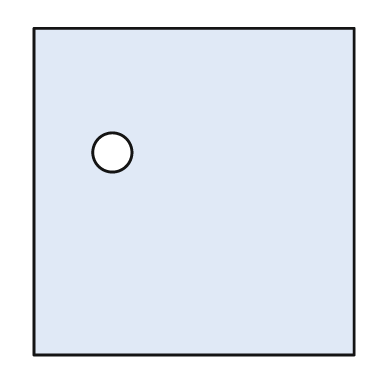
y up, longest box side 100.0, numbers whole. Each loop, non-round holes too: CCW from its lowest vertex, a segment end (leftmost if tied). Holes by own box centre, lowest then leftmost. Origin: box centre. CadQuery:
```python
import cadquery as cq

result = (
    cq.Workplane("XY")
    .moveTo(-49.0, -50.0)
    .lineTo(49.0, -50.0)
    .lineTo(49.0, 50.0)
    .lineTo(-49.0, 50.0)
    .close()
    .moveTo(-25.0, 12.0)
    .circle(6.0)
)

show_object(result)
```